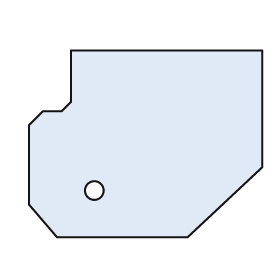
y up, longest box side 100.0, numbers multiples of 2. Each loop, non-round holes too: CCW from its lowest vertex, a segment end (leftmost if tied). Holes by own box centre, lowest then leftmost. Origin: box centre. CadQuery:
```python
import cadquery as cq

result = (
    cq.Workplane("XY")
    .moveTo(-38.0, -40.0)
    .lineTo(18.0, -40.0)
    .lineTo(50.0, -10.0)
    .lineTo(50.0, 40.0)
    .lineTo(-32.0, 40.0)
    .lineTo(-32.0, 18.0)
    .lineTo(-36.0, 14.0)
    .lineTo(-44.0, 14.0)
    .lineTo(-50.0, 8.0)
    .lineTo(-50.0, -26.0)
    .close()
    .moveTo(-22.0, -20.0)
    .circle(4.0)
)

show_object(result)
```